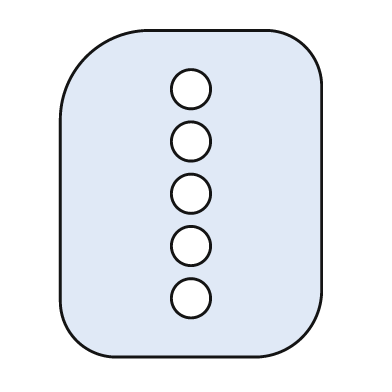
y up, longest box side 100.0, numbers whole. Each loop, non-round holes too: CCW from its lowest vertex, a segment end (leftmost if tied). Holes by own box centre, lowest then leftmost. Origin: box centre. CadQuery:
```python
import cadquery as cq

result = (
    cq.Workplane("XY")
    .moveTo(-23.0, -50.0)
    .lineTo(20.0, -50.0)
    .threePointArc((34.0, -44.0), (40.0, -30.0))
    .lineTo(40.0, 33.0)
    .threePointArc((35.0, 45.0), (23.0, 50.0))
    .lineTo(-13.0, 50.0)
    .threePointArc((-32.0, 42.0), (-40.0, 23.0))
    .lineTo(-40.0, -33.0)
    .threePointArc((-35.0, -45.0), (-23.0, -50.0))
    .close()
    .moveTo(0.0, -32.0)
    .circle(6.0)
    .moveTo(0.0, -16.0)
    .circle(6.0)
    .moveTo(0.0, 0.0)
    .circle(6.0)
    .moveTo(0.0, 16.0)
    .circle(6.0)
    .moveTo(0.0, 32.0)
    .circle(6.0)
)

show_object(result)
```